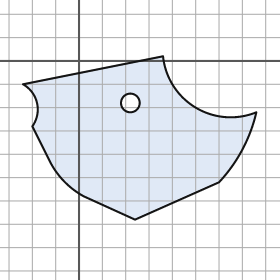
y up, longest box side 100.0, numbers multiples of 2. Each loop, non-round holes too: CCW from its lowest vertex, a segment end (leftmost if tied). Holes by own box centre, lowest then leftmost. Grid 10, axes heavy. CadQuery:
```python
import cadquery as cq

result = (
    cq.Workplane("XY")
    .moveTo(24.0, -68.0)
    .lineTo(60.0, -52.0)
    .threePointArc((70.0, -38.0), (76.0, -22.0))
    .threePointArc((50.0, -20.0), (36.0, 2.0))
    .lineTo(-24.0, -10.0)
    .threePointArc((-18.0, -18.0), (-20.0, -28.0))
    .lineTo(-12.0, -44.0)
    .threePointArc((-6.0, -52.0), (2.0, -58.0))
    .close()
    .moveTo(22.0, -18.0)
    .circle(4.0)
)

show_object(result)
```